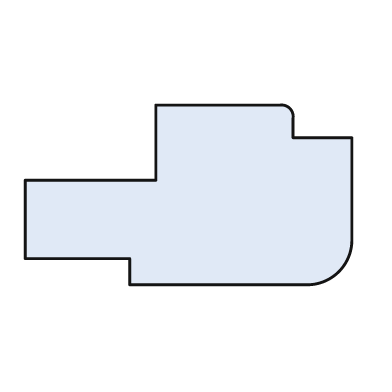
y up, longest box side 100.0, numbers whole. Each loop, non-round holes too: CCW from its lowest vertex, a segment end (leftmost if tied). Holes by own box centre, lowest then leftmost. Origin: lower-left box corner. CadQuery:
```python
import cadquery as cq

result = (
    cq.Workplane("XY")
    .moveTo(32.0, 0.0)
    .lineTo(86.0, 0.0)
    .threePointArc((96.0, 4.0), (100.0, 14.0))
    .lineTo(100.0, 45.0)
    .lineTo(82.0, 45.0)
    .lineTo(82.0, 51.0)
    .threePointArc((81.0, 54.0), (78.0, 55.0))
    .lineTo(40.0, 55.0)
    .lineTo(40.0, 32.0)
    .lineTo(0.0, 32.0)
    .lineTo(0.0, 8.0)
    .lineTo(32.0, 8.0)
    .close()
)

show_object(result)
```